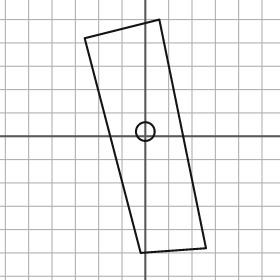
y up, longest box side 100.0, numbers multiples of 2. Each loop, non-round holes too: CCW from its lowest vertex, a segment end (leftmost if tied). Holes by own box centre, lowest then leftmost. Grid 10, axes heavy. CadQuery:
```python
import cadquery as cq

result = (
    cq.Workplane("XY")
    .moveTo(-2.0, -50.0)
    .lineTo(26.0, -48.0)
    .lineTo(6.0, 50.0)
    .lineTo(-26.0, 42.0)
    .close()
    .moveTo(0.0, 2.0)
    .circle(4.0)
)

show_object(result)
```